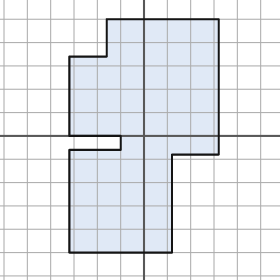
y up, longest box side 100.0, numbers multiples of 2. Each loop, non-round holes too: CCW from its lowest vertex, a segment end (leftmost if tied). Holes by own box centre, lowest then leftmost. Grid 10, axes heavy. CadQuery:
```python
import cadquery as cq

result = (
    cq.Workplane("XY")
    .moveTo(-32.0, -50.0)
    .lineTo(12.0, -50.0)
    .lineTo(12.0, -8.0)
    .lineTo(32.0, -8.0)
    .lineTo(32.0, 50.0)
    .lineTo(-16.0, 50.0)
    .lineTo(-16.0, 34.0)
    .lineTo(-32.0, 34.0)
    .lineTo(-32.0, 0.0)
    .lineTo(-10.0, 0.0)
    .lineTo(-10.0, -6.0)
    .lineTo(-32.0, -6.0)
    .close()
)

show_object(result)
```